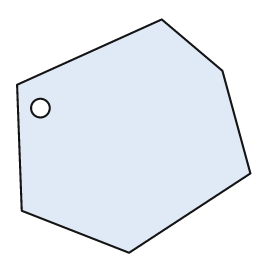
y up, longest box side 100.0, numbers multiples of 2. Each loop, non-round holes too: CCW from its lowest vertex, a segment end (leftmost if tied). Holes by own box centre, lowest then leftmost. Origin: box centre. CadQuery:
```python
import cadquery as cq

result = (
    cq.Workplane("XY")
    .moveTo(-2.0, -50.0)
    .lineTo(50.0, -16.0)
    .lineTo(38.0, 28.0)
    .lineTo(12.0, 50.0)
    .lineTo(-50.0, 22.0)
    .lineTo(-48.0, -32.0)
    .close()
    .moveTo(-40.0, 12.0)
    .circle(4.0)
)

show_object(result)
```